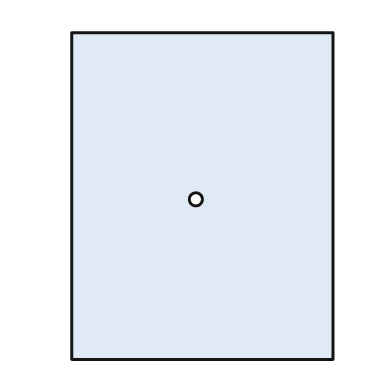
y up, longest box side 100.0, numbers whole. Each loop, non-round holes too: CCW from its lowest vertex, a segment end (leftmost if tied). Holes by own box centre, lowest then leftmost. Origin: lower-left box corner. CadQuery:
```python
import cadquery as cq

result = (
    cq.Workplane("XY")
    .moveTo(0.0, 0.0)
    .lineTo(80.0, 0.0)
    .lineTo(80.0, 100.0)
    .lineTo(0.0, 100.0)
    .close()
    .moveTo(38.0, 49.0)
    .circle(2.0)
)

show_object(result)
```